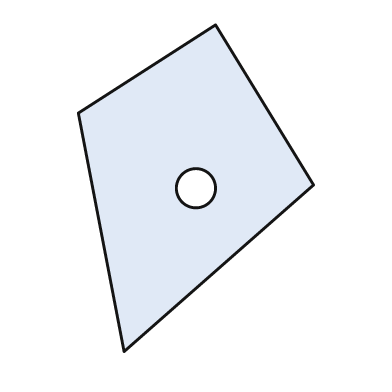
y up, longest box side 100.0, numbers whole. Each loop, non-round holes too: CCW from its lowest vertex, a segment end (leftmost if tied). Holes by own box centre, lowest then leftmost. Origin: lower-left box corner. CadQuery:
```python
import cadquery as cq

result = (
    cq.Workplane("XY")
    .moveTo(14.0, 0.0)
    .lineTo(72.0, 51.0)
    .lineTo(42.0, 100.0)
    .lineTo(0.0, 73.0)
    .close()
    .moveTo(36.0, 50.0)
    .circle(6.0)
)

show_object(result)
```